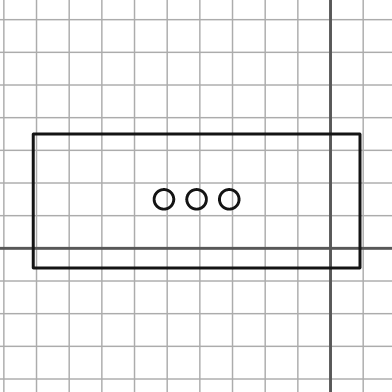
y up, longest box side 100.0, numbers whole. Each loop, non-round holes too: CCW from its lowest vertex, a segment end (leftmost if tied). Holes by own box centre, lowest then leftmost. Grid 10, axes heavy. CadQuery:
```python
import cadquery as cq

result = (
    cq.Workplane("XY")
    .moveTo(-91.0, -6.0)
    .lineTo(9.0, -6.0)
    .lineTo(9.0, 35.0)
    .lineTo(-91.0, 35.0)
    .close()
    .moveTo(-51.0, 15.0)
    .circle(3.0)
    .moveTo(-41.0, 15.0)
    .circle(3.0)
    .moveTo(-31.0, 15.0)
    .circle(3.0)
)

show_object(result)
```